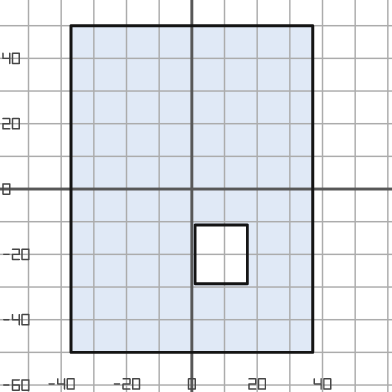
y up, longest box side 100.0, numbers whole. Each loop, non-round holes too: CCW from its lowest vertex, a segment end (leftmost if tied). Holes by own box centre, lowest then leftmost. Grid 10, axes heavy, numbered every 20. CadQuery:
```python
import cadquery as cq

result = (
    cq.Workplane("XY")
    .moveTo(-37.0, -50.0)
    .lineTo(37.0, -50.0)
    .lineTo(37.0, 50.0)
    .lineTo(-37.0, 50.0)
    .close()
    .moveTo(1.0, -29.0)
    .lineTo(17.0, -29.0)
    .lineTo(17.0, -11.0)
    .lineTo(1.0, -11.0)
    .close()
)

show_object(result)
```